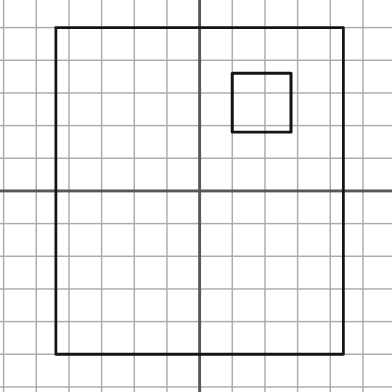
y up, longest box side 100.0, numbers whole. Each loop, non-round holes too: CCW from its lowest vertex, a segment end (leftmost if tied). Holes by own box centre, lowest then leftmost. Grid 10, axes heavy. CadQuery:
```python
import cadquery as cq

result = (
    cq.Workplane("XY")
    .moveTo(-44.0, -50.0)
    .lineTo(44.0, -50.0)
    .lineTo(44.0, 50.0)
    .lineTo(-44.0, 50.0)
    .close()
    .moveTo(10.0, 18.0)
    .lineTo(28.0, 18.0)
    .lineTo(28.0, 36.0)
    .lineTo(10.0, 36.0)
    .close()
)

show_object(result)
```